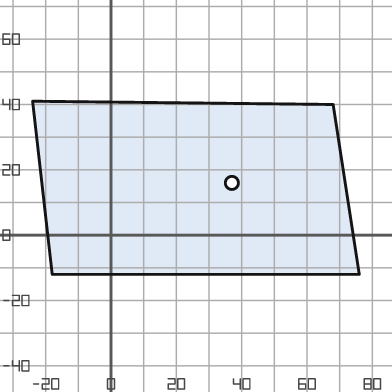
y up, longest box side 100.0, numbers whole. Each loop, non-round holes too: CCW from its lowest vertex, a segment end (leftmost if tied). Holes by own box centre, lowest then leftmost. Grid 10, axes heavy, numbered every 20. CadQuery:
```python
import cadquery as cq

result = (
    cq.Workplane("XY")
    .moveTo(-18.0, -12.0)
    .lineTo(76.0, -12.0)
    .lineTo(68.0, 40.0)
    .lineTo(-24.0, 41.0)
    .close()
    .moveTo(37.0, 16.0)
    .circle(2.0)
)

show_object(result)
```